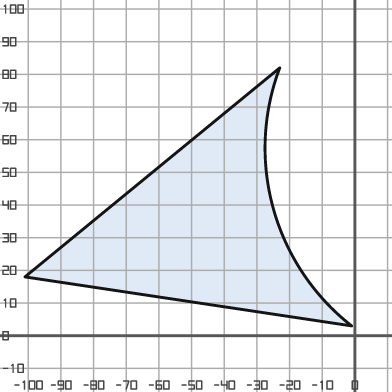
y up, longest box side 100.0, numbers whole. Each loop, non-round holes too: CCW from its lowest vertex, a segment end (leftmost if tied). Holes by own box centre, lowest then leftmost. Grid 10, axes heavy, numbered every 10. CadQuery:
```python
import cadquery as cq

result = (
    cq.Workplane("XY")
    .moveTo(-1.0, 3.0)
    .threePointArc((-25.0, 39.0), (-23.0, 82.0))
    .lineTo(-101.0, 18.0)
    .close()
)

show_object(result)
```